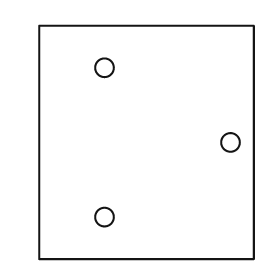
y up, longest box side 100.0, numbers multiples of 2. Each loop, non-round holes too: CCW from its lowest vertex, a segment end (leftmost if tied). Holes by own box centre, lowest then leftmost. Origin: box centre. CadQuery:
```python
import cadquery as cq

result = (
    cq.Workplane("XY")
    .moveTo(-46.0, -50.0)
    .lineTo(46.0, -50.0)
    .lineTo(46.0, 50.0)
    .lineTo(-46.0, 50.0)
    .close()
    .moveTo(-18.0, -32.0)
    .circle(4.0)
    .moveTo(36.0, 0.0)
    .circle(4.0)
    .moveTo(-18.0, 32.0)
    .circle(4.0)
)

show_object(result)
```